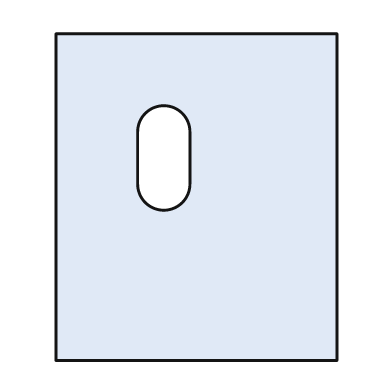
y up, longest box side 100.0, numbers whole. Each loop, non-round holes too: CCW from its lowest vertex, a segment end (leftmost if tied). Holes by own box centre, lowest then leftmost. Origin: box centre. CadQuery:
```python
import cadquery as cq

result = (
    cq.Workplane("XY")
    .moveTo(-43.0, -50.0)
    .lineTo(43.0, -50.0)
    .lineTo(43.0, 50.0)
    .lineTo(-43.0, 50.0)
    .close()
    .moveTo(-18.0, 4.0)
    .threePointArc((-10.0, -4.0), (-2.0, 4.0))
    .lineTo(-2.0, 20.0)
    .threePointArc((-10.0, 28.0), (-18.0, 20.0))
    .close()
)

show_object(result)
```